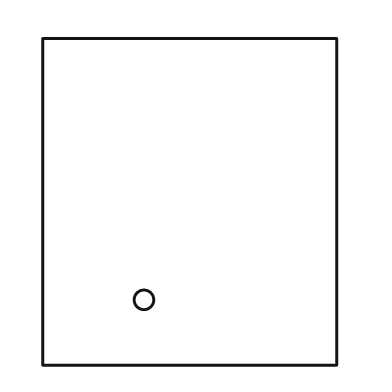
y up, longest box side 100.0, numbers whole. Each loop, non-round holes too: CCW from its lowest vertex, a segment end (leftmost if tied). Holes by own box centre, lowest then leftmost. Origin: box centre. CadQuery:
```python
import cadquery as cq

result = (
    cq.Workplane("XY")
    .moveTo(-45.0, -50.0)
    .lineTo(45.0, -50.0)
    .lineTo(45.0, 50.0)
    .lineTo(-45.0, 50.0)
    .close()
    .moveTo(-14.0, -30.0)
    .circle(3.0)
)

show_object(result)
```